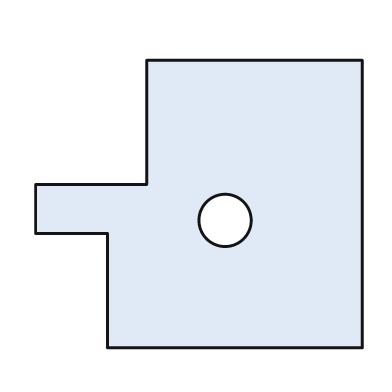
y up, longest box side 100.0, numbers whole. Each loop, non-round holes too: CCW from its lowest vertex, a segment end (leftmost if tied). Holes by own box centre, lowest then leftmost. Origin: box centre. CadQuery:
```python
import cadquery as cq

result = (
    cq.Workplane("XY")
    .moveTo(-28.0, -44.0)
    .lineTo(50.0, -44.0)
    .lineTo(50.0, 44.0)
    .lineTo(-16.0, 44.0)
    .lineTo(-16.0, 6.0)
    .lineTo(-50.0, 6.0)
    .lineTo(-50.0, -9.0)
    .lineTo(-28.0, -9.0)
    .close()
    .moveTo(8.0, -5.0)
    .circle(8.0)
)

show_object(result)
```